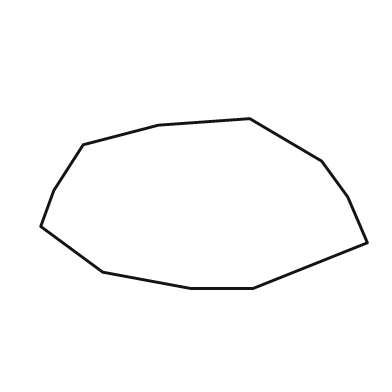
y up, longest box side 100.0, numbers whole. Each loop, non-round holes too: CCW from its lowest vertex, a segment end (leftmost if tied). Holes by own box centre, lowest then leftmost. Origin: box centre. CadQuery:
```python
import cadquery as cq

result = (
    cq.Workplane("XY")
    .moveTo(-4.0, -26.0)
    .lineTo(15.0, -26.0)
    .lineTo(50.0, -12.0)
    .lineTo(44.0, 2.0)
    .lineTo(36.0, 13.0)
    .lineTo(14.0, 26.0)
    .lineTo(-14.0, 24.0)
    .lineTo(-37.0, 18.0)
    .lineTo(-46.0, 4.0)
    .lineTo(-50.0, -7.0)
    .lineTo(-31.0, -21.0)
    .close()
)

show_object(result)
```